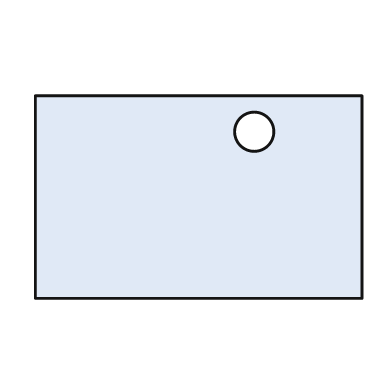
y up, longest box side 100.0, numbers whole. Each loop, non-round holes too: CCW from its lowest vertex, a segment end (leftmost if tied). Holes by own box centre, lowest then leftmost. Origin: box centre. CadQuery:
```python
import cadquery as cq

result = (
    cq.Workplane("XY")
    .moveTo(-50.0, -31.0)
    .lineTo(50.0, -31.0)
    .lineTo(50.0, 31.0)
    .lineTo(-50.0, 31.0)
    .close()
    .moveTo(17.0, 20.0)
    .circle(6.0)
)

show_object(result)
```